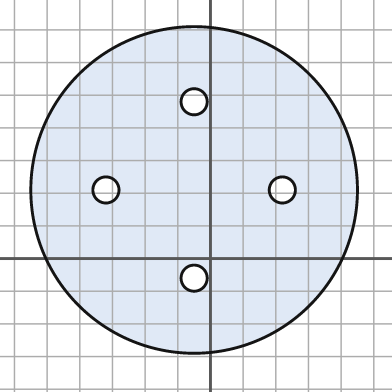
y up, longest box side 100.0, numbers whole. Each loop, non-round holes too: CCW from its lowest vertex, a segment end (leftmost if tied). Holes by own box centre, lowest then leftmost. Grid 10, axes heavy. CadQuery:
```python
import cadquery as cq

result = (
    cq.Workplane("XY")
    .moveTo(-5.0, 21.0)
    .circle(50.0)
    .moveTo(-5.0, -6.0)
    .circle(4.0)
    .moveTo(-32.0, 21.0)
    .circle(4.0)
    .moveTo(22.0, 21.0)
    .circle(4.0)
    .moveTo(-5.0, 48.0)
    .circle(4.0)
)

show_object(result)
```